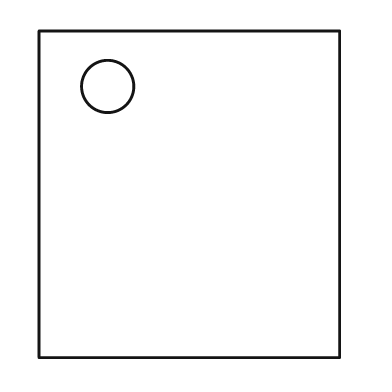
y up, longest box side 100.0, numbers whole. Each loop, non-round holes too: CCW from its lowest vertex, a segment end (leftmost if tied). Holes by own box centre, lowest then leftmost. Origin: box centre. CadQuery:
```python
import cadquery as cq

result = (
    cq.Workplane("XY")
    .moveTo(-46.0, -50.0)
    .lineTo(46.0, -50.0)
    .lineTo(46.0, 50.0)
    .lineTo(-46.0, 50.0)
    .close()
    .moveTo(-25.0, 33.0)
    .circle(8.0)
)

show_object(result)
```